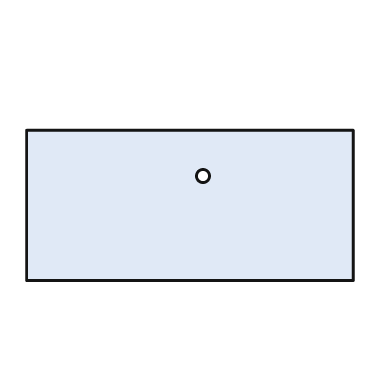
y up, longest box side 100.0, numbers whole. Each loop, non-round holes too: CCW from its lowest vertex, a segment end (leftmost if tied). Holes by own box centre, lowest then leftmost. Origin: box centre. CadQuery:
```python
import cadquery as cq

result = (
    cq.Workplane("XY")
    .moveTo(-50.0, -23.0)
    .lineTo(50.0, -23.0)
    .lineTo(50.0, 23.0)
    .lineTo(-50.0, 23.0)
    .close()
    .moveTo(4.0, 9.0)
    .circle(2.0)
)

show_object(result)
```